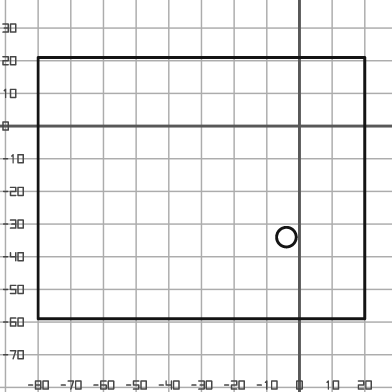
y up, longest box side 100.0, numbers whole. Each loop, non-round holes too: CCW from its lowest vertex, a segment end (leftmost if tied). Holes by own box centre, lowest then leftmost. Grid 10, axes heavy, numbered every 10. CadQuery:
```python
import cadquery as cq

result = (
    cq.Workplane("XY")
    .moveTo(-80.0, -59.0)
    .lineTo(20.0, -59.0)
    .lineTo(20.0, 21.0)
    .lineTo(-80.0, 21.0)
    .close()
    .moveTo(-4.0, -34.0)
    .circle(3.0)
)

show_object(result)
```